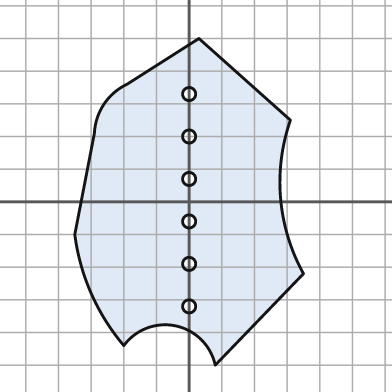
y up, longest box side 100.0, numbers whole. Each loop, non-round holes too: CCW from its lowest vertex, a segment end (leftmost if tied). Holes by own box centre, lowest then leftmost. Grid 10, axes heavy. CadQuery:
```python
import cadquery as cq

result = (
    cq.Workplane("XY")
    .moveTo(8.0, -50.0)
    .lineTo(35.0, -22.0)
    .threePointArc((28.0, 1.0), (31.0, 25.0))
    .lineTo(3.0, 50.0)
    .lineTo(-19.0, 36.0)
    .threePointArc((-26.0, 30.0), (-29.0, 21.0))
    .lineTo(-35.0, -10.0)
    .threePointArc((-30.0, -28.0), (-20.0, -44.0))
    .threePointArc((-4.0, -38.0), (8.0, -50.0))
    .close()
    .moveTo(0.0, -32.0)
    .circle(2.0)
    .moveTo(0.0, -19.0)
    .circle(2.0)
    .moveTo(0.0, -6.0)
    .circle(2.0)
    .moveTo(0.0, 7.0)
    .circle(2.0)
    .moveTo(0.0, 20.0)
    .circle(2.0)
    .moveTo(0.0, 33.0)
    .circle(2.0)
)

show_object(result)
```